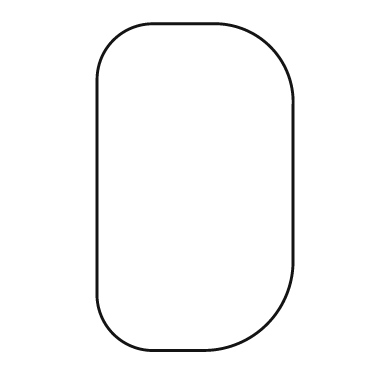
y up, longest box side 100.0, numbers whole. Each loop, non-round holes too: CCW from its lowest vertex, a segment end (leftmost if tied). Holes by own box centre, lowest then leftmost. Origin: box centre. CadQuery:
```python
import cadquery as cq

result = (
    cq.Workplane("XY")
    .moveTo(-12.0, -50.0)
    .lineTo(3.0, -50.0)
    .threePointArc((22.0, -42.0), (30.0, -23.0))
    .lineTo(30.0, 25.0)
    .threePointArc((23.0, 43.0), (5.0, 50.0))
    .lineTo(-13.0, 50.0)
    .threePointArc((-25.0, 45.0), (-30.0, 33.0))
    .lineTo(-30.0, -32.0)
    .threePointArc((-25.0, -45.0), (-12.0, -50.0))
    .close()
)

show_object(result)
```